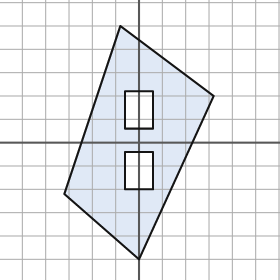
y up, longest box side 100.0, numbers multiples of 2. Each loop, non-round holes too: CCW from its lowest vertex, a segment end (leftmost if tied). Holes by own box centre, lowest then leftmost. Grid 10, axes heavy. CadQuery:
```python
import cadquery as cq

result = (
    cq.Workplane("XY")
    .moveTo(0.0, -50.0)
    .lineTo(32.0, 20.0)
    .lineTo(-8.0, 50.0)
    .lineTo(-32.0, -22.0)
    .close()
    .moveTo(-6.0, -20.0)
    .lineTo(6.0, -20.0)
    .lineTo(6.0, -4.0)
    .lineTo(-6.0, -4.0)
    .close()
    .moveTo(-6.0, 6.0)
    .lineTo(6.0, 6.0)
    .lineTo(6.0, 22.0)
    .lineTo(-6.0, 22.0)
    .close()
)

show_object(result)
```